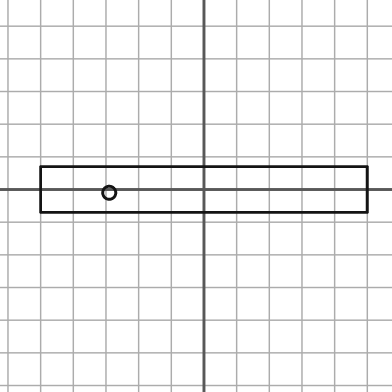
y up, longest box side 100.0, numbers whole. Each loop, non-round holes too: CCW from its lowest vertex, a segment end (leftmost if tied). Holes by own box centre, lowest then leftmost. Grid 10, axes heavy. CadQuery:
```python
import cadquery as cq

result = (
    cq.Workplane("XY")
    .moveTo(-50.0, -7.0)
    .lineTo(50.0, -7.0)
    .lineTo(50.0, 7.0)
    .lineTo(-50.0, 7.0)
    .close()
    .moveTo(-29.0, -1.0)
    .circle(2.0)
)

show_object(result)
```